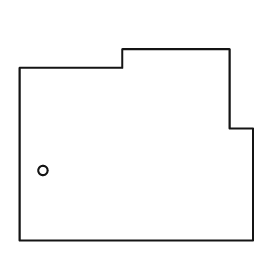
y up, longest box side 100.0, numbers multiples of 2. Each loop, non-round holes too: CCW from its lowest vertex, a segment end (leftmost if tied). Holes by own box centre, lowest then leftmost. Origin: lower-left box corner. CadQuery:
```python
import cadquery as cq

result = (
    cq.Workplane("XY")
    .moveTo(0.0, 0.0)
    .lineTo(100.0, 0.0)
    .lineTo(100.0, 48.0)
    .lineTo(90.0, 48.0)
    .lineTo(90.0, 82.0)
    .lineTo(44.0, 82.0)
    .lineTo(44.0, 74.0)
    .lineTo(0.0, 74.0)
    .close()
    .moveTo(10.0, 30.0)
    .circle(2.0)
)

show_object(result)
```